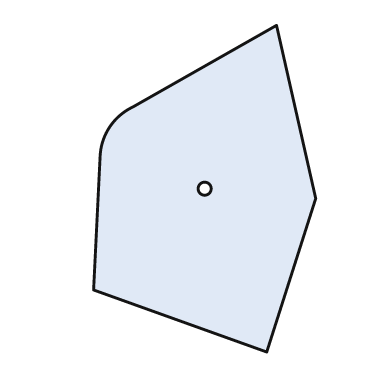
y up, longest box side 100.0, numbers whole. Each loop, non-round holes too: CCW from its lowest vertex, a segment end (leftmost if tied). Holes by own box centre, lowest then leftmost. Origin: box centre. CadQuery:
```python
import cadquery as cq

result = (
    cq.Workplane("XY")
    .moveTo(19.0, -50.0)
    .lineTo(34.0, -3.0)
    .lineTo(22.0, 50.0)
    .lineTo(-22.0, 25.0)
    .threePointArc((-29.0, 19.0), (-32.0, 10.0))
    .lineTo(-34.0, -31.0)
    .close()
    .moveTo(0.0, 0.0)
    .circle(2.0)
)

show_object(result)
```